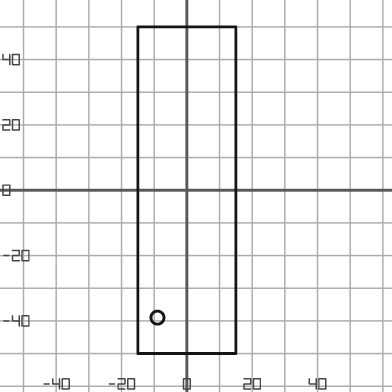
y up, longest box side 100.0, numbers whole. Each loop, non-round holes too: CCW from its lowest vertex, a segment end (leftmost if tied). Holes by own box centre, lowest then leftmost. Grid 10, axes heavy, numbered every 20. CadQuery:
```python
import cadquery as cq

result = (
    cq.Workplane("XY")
    .moveTo(-15.0, -50.0)
    .lineTo(15.0, -50.0)
    .lineTo(15.0, 50.0)
    .lineTo(-15.0, 50.0)
    .close()
    .moveTo(-9.0, -39.0)
    .circle(2.0)
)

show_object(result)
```